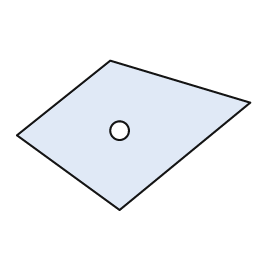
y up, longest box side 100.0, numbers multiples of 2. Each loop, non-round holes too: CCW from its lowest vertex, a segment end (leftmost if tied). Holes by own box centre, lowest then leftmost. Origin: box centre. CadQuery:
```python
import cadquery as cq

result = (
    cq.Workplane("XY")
    .moveTo(-6.0, -32.0)
    .lineTo(50.0, 14.0)
    .lineTo(-10.0, 32.0)
    .lineTo(-50.0, 0.0)
    .close()
    .moveTo(-6.0, 2.0)
    .circle(4.0)
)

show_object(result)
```